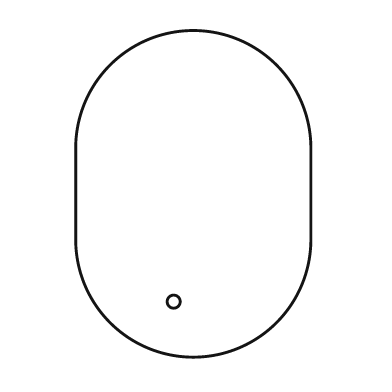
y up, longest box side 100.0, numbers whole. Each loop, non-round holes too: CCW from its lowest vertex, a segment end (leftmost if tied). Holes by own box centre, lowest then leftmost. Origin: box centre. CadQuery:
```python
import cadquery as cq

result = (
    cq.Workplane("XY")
    .moveTo(-36.0, -14.0)
    .threePointArc((0.0, -50.0), (36.0, -14.0))
    .lineTo(36.0, 14.0)
    .threePointArc((0.0, 50.0), (-36.0, 14.0))
    .close()
    .moveTo(-6.0, -33.0)
    .circle(2.0)
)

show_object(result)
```